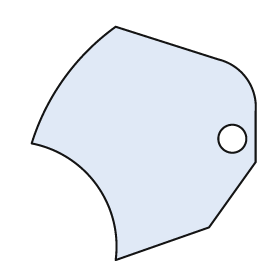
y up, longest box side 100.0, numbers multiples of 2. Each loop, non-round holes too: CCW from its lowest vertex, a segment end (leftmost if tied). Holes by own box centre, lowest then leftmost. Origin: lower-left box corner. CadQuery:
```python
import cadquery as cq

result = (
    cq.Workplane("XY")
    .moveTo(36.0, 0.0)
    .lineTo(76.0, 14.0)
    .lineTo(96.0, 42.0)
    .lineTo(96.0, 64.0)
    .threePointArc((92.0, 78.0), (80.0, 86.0))
    .lineTo(36.0, 100.0)
    .threePointArc((14.0, 78.0), (0.0, 50.0))
    .threePointArc((28.0, 32.0), (36.0, 0.0))
    .close()
    .moveTo(86.0, 52.0)
    .circle(6.0)
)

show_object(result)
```